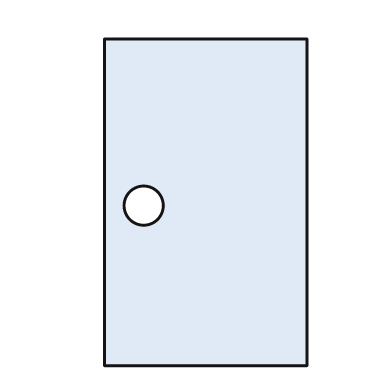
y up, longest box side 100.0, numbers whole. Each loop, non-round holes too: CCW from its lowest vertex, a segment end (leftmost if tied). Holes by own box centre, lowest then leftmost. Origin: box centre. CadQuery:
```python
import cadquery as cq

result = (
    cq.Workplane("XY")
    .moveTo(-31.0, -50.0)
    .lineTo(31.0, -50.0)
    .lineTo(31.0, 50.0)
    .lineTo(-31.0, 50.0)
    .close()
    .moveTo(-19.0, -1.0)
    .circle(6.0)
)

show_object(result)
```